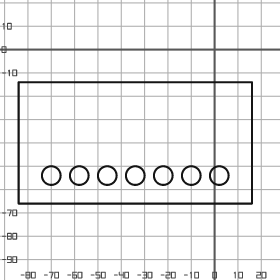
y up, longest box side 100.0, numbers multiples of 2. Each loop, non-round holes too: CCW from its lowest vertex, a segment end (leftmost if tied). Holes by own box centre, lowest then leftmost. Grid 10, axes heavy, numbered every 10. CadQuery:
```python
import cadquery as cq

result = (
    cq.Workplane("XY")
    .moveTo(-84.0, -66.0)
    .lineTo(16.0, -66.0)
    .lineTo(16.0, -14.0)
    .lineTo(-84.0, -14.0)
    .close()
    .moveTo(-70.0, -54.0)
    .circle(4.0)
    .moveTo(-58.0, -54.0)
    .circle(4.0)
    .moveTo(-46.0, -54.0)
    .circle(4.0)
    .moveTo(-34.0, -54.0)
    .circle(4.0)
    .moveTo(-22.0, -54.0)
    .circle(4.0)
    .moveTo(-10.0, -54.0)
    .circle(4.0)
    .moveTo(2.0, -54.0)
    .circle(4.0)
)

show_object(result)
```